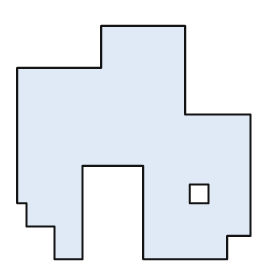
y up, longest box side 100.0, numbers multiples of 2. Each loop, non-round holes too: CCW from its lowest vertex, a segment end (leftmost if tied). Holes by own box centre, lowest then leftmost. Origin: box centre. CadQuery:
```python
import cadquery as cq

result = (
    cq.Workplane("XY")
    .moveTo(-34.0, -50.0)
    .lineTo(-22.0, -50.0)
    .lineTo(-22.0, -10.0)
    .lineTo(4.0, -10.0)
    .lineTo(4.0, -50.0)
    .lineTo(40.0, -50.0)
    .lineTo(40.0, -40.0)
    .lineTo(50.0, -40.0)
    .lineTo(50.0, 12.0)
    .lineTo(22.0, 12.0)
    .lineTo(22.0, 50.0)
    .lineTo(-14.0, 50.0)
    .lineTo(-14.0, 32.0)
    .lineTo(-50.0, 32.0)
    .lineTo(-50.0, -26.0)
    .lineTo(-46.0, -26.0)
    .lineTo(-46.0, -36.0)
    .lineTo(-34.0, -36.0)
    .close()
    .moveTo(24.0, -26.0)
    .lineTo(32.0, -26.0)
    .lineTo(32.0, -18.0)
    .lineTo(24.0, -18.0)
    .close()
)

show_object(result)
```